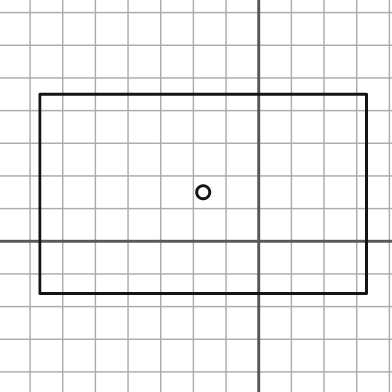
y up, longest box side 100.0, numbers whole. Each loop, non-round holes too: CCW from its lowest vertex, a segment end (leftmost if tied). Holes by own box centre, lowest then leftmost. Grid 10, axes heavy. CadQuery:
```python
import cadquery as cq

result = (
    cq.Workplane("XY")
    .moveTo(-67.0, -16.0)
    .lineTo(33.0, -16.0)
    .lineTo(33.0, 45.0)
    .lineTo(-67.0, 45.0)
    .close()
    .moveTo(-17.0, 15.0)
    .circle(2.0)
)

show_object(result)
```